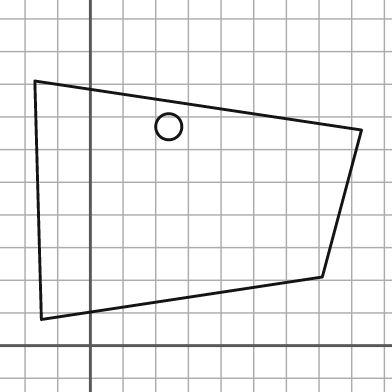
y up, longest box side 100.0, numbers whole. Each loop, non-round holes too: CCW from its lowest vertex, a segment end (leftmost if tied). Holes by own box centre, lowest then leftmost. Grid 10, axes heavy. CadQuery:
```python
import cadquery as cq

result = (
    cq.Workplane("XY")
    .moveTo(-15.0, 8.0)
    .lineTo(71.0, 21.0)
    .lineTo(83.0, 66.0)
    .lineTo(-17.0, 81.0)
    .close()
    .moveTo(24.0, 67.0)
    .circle(4.0)
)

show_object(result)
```